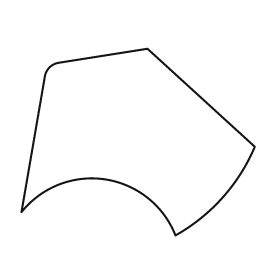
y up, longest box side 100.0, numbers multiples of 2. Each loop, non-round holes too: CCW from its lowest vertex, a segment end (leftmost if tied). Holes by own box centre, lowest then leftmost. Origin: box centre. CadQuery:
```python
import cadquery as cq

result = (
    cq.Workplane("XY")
    .moveTo(16.0, -40.0)
    .threePointArc((36.0, -24.0), (50.0, -2.0))
    .lineTo(4.0, 40.0)
    .lineTo(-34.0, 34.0)
    .threePointArc((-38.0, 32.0), (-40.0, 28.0))
    .lineTo(-50.0, -30.0)
    .threePointArc((-14.0, -16.0), (16.0, -40.0))
    .close()
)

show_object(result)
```